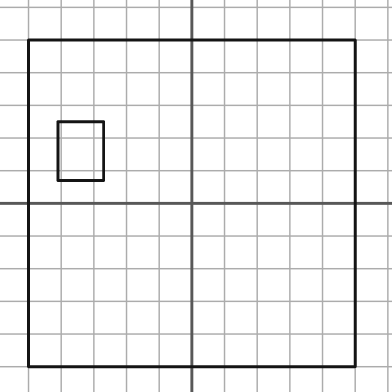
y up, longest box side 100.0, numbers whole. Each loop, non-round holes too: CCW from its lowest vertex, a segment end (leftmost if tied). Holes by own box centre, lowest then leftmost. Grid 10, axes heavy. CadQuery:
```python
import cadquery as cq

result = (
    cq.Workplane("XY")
    .moveTo(-50.0, -50.0)
    .lineTo(50.0, -50.0)
    .lineTo(50.0, 50.0)
    .lineTo(-50.0, 50.0)
    .close()
    .moveTo(-41.0, 7.0)
    .lineTo(-27.0, 7.0)
    .lineTo(-27.0, 25.0)
    .lineTo(-41.0, 25.0)
    .close()
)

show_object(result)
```